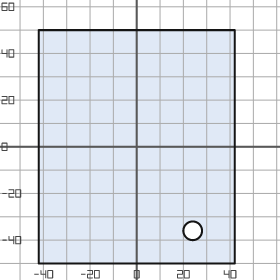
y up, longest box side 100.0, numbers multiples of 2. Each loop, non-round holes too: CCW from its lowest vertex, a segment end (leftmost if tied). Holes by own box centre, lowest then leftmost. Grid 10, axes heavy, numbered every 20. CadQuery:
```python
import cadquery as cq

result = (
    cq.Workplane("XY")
    .moveTo(-42.0, -50.0)
    .lineTo(42.0, -50.0)
    .lineTo(42.0, 50.0)
    .lineTo(-42.0, 50.0)
    .close()
    .moveTo(24.0, -36.0)
    .circle(4.0)
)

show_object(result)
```